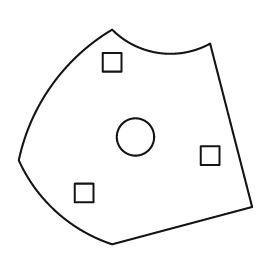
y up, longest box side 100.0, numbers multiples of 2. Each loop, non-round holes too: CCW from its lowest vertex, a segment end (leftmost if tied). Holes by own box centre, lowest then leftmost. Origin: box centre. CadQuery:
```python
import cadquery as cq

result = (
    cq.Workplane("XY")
    .moveTo(-10.0, -46.0)
    .lineTo(50.0, -30.0)
    .lineTo(32.0, 40.0)
    .threePointArc((10.0, 36.0), (-10.0, 46.0))
    .threePointArc((-36.0, 22.0), (-50.0, -10.0))
    .threePointArc((-34.0, -32.0), (-10.0, -46.0))
    .close()
    .moveTo(-26.0, -28.0)
    .lineTo(-18.0, -28.0)
    .lineTo(-18.0, -20.0)
    .lineTo(-26.0, -20.0)
    .close()
    .moveTo(28.0, -12.0)
    .lineTo(36.0, -12.0)
    .lineTo(36.0, -4.0)
    .lineTo(28.0, -4.0)
    .close()
    .moveTo(0.0, 0.0)
    .circle(8.0)
    .moveTo(-14.0, 28.0)
    .lineTo(-6.0, 28.0)
    .lineTo(-6.0, 36.0)
    .lineTo(-14.0, 36.0)
    .close()
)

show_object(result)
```